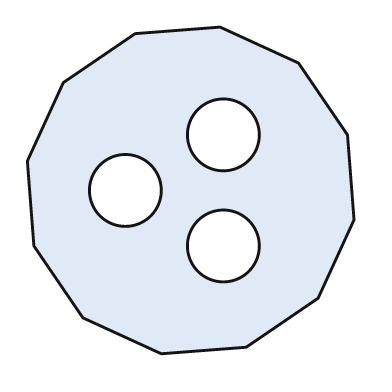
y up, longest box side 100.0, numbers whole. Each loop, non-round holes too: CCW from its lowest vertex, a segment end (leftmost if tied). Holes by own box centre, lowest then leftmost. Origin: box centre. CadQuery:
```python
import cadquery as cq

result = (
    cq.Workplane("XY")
    .moveTo(-9.0, -50.0)
    .lineTo(17.0, -48.0)
    .lineTo(39.0, -33.0)
    .lineTo(50.0, -9.0)
    .lineTo(48.0, 17.0)
    .lineTo(33.0, 39.0)
    .lineTo(9.0, 50.0)
    .lineTo(-17.0, 48.0)
    .lineTo(-39.0, 33.0)
    .lineTo(-50.0, 9.0)
    .lineTo(-48.0, -17.0)
    .lineTo(-33.0, -39.0)
    .close()
    .moveTo(10.0, -17.0)
    .circle(11.0)
    .moveTo(-20.0, 0.0)
    .circle(11.0)
    .moveTo(10.0, 17.0)
    .circle(11.0)
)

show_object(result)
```